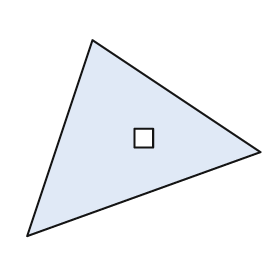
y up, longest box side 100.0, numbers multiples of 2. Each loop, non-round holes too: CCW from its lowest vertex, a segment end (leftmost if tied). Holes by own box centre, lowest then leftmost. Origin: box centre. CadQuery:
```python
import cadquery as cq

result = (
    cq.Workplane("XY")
    .moveTo(-50.0, -42.0)
    .lineTo(50.0, -6.0)
    .lineTo(-22.0, 42.0)
    .close()
    .moveTo(-4.0, -4.0)
    .lineTo(4.0, -4.0)
    .lineTo(4.0, 4.0)
    .lineTo(-4.0, 4.0)
    .close()
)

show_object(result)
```